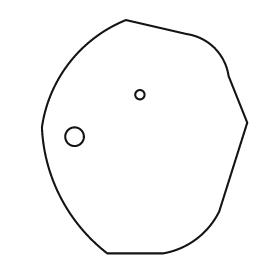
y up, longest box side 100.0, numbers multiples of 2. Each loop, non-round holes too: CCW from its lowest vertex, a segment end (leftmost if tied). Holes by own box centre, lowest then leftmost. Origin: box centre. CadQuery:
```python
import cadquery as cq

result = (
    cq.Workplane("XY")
    .moveTo(-16.0, -50.0)
    .lineTo(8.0, -50.0)
    .threePointArc((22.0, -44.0), (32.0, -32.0))
    .lineTo(44.0, 6.0)
    .lineTo(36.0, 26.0)
    .threePointArc((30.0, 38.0), (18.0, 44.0))
    .lineTo(-8.0, 50.0)
    .threePointArc((-32.0, 32.0), (-44.0, 4.0))
    .threePointArc((-36.0, -26.0), (-16.0, -50.0))
    .close()
    .moveTo(-30.0, 0.0)
    .circle(4.0)
    .moveTo(-2.0, 18.0)
    .circle(2.0)
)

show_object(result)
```